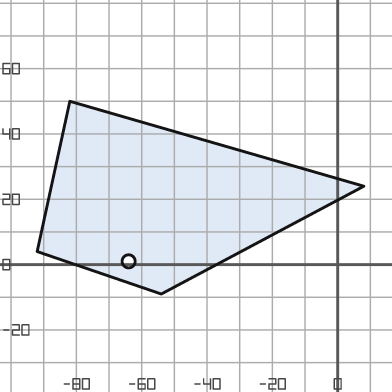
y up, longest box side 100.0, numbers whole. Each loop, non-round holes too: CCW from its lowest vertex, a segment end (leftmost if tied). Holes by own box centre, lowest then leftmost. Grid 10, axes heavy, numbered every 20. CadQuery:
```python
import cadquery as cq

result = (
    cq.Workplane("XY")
    .moveTo(-54.0, -9.0)
    .lineTo(8.0, 24.0)
    .lineTo(-82.0, 50.0)
    .lineTo(-92.0, 4.0)
    .close()
    .moveTo(-64.0, 1.0)
    .circle(2.0)
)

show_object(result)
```